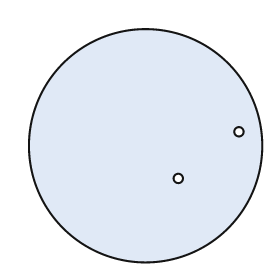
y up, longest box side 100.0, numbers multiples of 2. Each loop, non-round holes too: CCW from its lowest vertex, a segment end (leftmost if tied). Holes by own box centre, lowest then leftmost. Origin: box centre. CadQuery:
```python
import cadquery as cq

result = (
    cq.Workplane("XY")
    .moveTo(0.0, 0.0)
    .circle(50.0)
    .moveTo(14.0, -14.0)
    .circle(2.0)
    .moveTo(40.0, 6.0)
    .circle(2.0)
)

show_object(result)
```